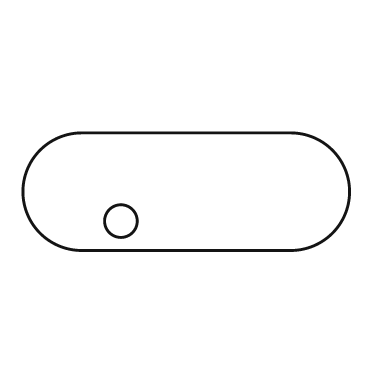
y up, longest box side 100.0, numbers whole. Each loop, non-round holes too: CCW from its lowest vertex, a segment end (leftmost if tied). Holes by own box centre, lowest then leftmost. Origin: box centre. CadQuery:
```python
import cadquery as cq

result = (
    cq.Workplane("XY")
    .moveTo(-32.0, -18.0)
    .lineTo(32.0, -18.0)
    .threePointArc((50.0, 0.0), (32.0, 18.0))
    .lineTo(-32.0, 18.0)
    .threePointArc((-50.0, 0.0), (-32.0, -18.0))
    .close()
    .moveTo(-20.0, -9.0)
    .circle(5.0)
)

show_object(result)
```